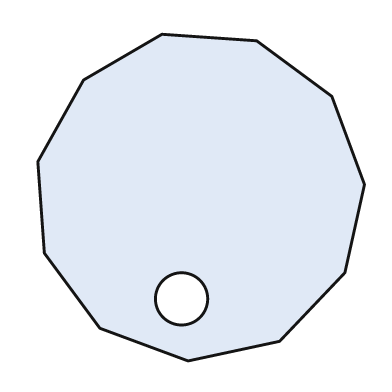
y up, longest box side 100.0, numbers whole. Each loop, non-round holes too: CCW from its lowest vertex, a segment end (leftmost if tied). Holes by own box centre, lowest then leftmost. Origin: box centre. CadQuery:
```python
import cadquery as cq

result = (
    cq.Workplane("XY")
    .moveTo(-4.0, -50.0)
    .lineTo(24.0, -44.0)
    .lineTo(44.0, -23.0)
    .lineTo(50.0, 4.0)
    .lineTo(40.0, 31.0)
    .lineTo(17.0, 48.0)
    .lineTo(-12.0, 50.0)
    .lineTo(-36.0, 36.0)
    .lineTo(-50.0, 11.0)
    .lineTo(-48.0, -17.0)
    .lineTo(-31.0, -40.0)
    .close()
    .moveTo(-6.0, -31.0)
    .circle(8.0)
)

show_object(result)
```